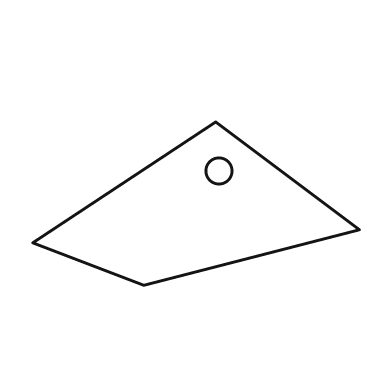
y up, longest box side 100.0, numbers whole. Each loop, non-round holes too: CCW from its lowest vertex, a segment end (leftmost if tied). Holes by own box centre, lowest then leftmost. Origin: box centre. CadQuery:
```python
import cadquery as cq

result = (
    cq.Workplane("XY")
    .moveTo(-16.0, -25.0)
    .lineTo(50.0, -8.0)
    .lineTo(6.0, 25.0)
    .lineTo(-50.0, -12.0)
    .close()
    .moveTo(7.0, 10.0)
    .circle(4.0)
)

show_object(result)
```